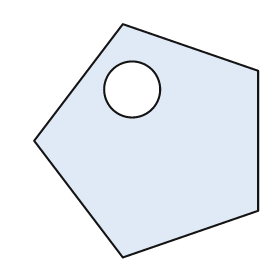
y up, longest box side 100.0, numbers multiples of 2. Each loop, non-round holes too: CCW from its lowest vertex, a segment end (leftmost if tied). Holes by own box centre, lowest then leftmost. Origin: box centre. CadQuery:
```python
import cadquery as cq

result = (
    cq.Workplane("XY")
    .moveTo(-10.0, -50.0)
    .lineTo(48.0, -30.0)
    .lineTo(48.0, 30.0)
    .lineTo(-10.0, 50.0)
    .lineTo(-48.0, 0.0)
    .close()
    .moveTo(-6.0, 22.0)
    .circle(12.0)
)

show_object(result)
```